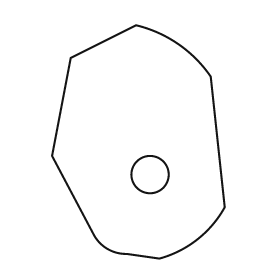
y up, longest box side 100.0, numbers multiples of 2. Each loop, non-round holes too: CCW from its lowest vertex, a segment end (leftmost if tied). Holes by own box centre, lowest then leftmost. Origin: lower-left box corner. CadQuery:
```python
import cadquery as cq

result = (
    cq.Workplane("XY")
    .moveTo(46.0, 0.0)
    .threePointArc((62.0, 8.0), (74.0, 22.0))
    .lineTo(68.0, 78.0)
    .threePointArc((54.0, 92.0), (36.0, 100.0))
    .lineTo(8.0, 86.0)
    .lineTo(0.0, 44.0)
    .lineTo(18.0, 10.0)
    .threePointArc((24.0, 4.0), (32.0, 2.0))
    .close()
    .moveTo(42.0, 36.0)
    .circle(8.0)
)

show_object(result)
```